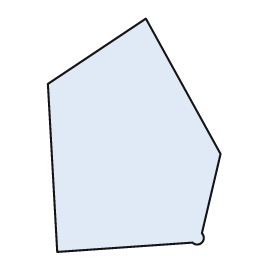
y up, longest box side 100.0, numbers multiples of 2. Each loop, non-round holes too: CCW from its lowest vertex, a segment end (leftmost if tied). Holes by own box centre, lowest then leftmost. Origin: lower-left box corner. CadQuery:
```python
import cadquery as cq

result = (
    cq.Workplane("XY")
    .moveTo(4.0, 0.0)
    .lineTo(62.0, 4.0)
    .threePointArc((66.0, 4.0), (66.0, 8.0))
    .lineTo(74.0, 42.0)
    .lineTo(42.0, 100.0)
    .lineTo(0.0, 72.0)
    .close()
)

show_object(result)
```